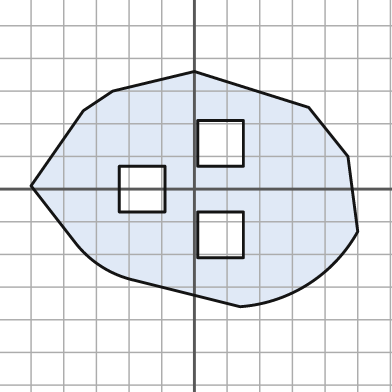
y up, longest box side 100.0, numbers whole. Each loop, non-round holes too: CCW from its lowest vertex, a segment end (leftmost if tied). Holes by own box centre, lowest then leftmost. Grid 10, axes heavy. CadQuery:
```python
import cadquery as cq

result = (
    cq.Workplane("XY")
    .moveTo(14.0, -36.0)
    .threePointArc((35.0, -29.0), (50.0, -13.0))
    .lineTo(47.0, 10.0)
    .lineTo(35.0, 25.0)
    .lineTo(0.0, 36.0)
    .lineTo(-25.0, 30.0)
    .lineTo(-34.0, 24.0)
    .lineTo(-50.0, 1.0)
    .lineTo(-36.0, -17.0)
    .threePointArc((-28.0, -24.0), (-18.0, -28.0))
    .close()
    .moveTo(1.0, -21.0)
    .lineTo(15.0, -21.0)
    .lineTo(15.0, -7.0)
    .lineTo(1.0, -7.0)
    .close()
    .moveTo(-23.0, -7.0)
    .lineTo(-9.0, -7.0)
    .lineTo(-9.0, 7.0)
    .lineTo(-23.0, 7.0)
    .close()
    .moveTo(1.0, 7.0)
    .lineTo(15.0, 7.0)
    .lineTo(15.0, 21.0)
    .lineTo(1.0, 21.0)
    .close()
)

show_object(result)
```